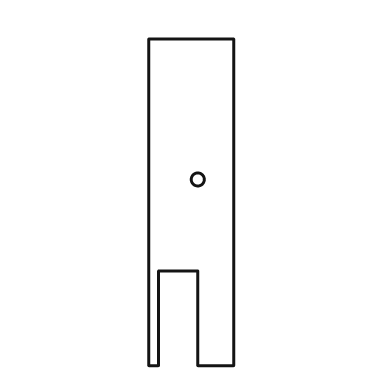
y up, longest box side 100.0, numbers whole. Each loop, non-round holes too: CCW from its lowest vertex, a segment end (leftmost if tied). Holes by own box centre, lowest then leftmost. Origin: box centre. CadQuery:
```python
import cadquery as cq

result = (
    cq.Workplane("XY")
    .moveTo(-13.0, -50.0)
    .lineTo(-10.0, -50.0)
    .lineTo(-10.0, -21.0)
    .lineTo(2.0, -21.0)
    .lineTo(2.0, -50.0)
    .lineTo(13.0, -50.0)
    .lineTo(13.0, 50.0)
    .lineTo(-13.0, 50.0)
    .close()
    .moveTo(2.0, 7.0)
    .circle(2.0)
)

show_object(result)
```